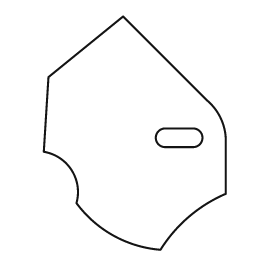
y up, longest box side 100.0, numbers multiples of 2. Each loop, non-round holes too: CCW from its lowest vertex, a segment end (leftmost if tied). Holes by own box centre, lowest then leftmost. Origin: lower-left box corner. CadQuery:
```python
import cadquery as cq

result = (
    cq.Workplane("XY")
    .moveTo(50.0, 0.0)
    .threePointArc((62.0, 14.0), (78.0, 24.0))
    .lineTo(78.0, 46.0)
    .threePointArc((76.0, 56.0), (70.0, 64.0))
    .lineTo(34.0, 100.0)
    .lineTo(2.0, 74.0)
    .lineTo(0.0, 42.0)
    .threePointArc((12.0, 34.0), (14.0, 20.0))
    .threePointArc((30.0, 6.0), (50.0, 0.0))
    .close()
    .moveTo(52.0, 44.0)
    .lineTo(64.0, 44.0)
    .threePointArc((68.0, 48.0), (64.0, 52.0))
    .lineTo(52.0, 52.0)
    .threePointArc((48.0, 48.0), (52.0, 44.0))
    .close()
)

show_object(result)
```